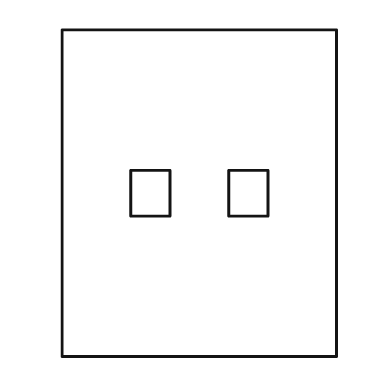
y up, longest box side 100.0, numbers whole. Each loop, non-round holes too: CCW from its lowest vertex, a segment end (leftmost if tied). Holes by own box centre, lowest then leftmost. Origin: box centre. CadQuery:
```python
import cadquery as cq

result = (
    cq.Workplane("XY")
    .moveTo(-42.0, -50.0)
    .lineTo(42.0, -50.0)
    .lineTo(42.0, 50.0)
    .lineTo(-42.0, 50.0)
    .close()
    .moveTo(-21.0, -7.0)
    .lineTo(-9.0, -7.0)
    .lineTo(-9.0, 7.0)
    .lineTo(-21.0, 7.0)
    .close()
    .moveTo(9.0, -7.0)
    .lineTo(21.0, -7.0)
    .lineTo(21.0, 7.0)
    .lineTo(9.0, 7.0)
    .close()
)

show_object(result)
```